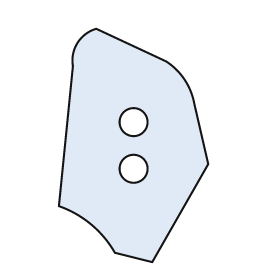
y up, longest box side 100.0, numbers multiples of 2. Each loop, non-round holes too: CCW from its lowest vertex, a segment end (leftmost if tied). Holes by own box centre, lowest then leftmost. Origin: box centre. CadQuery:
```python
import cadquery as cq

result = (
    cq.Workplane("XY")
    .moveTo(8.0, -50.0)
    .lineTo(32.0, -8.0)
    .lineTo(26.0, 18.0)
    .threePointArc((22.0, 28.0), (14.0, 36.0))
    .lineTo(-16.0, 50.0)
    .threePointArc((-24.0, 44.0), (-26.0, 34.0))
    .lineTo(-32.0, -26.0)
    .threePointArc((-18.0, -34.0), (-8.0, -46.0))
    .close()
    .moveTo(0.0, -10.0)
    .circle(6.0)
    .moveTo(0.0, 10.0)
    .circle(6.0)
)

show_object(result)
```